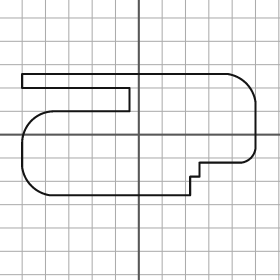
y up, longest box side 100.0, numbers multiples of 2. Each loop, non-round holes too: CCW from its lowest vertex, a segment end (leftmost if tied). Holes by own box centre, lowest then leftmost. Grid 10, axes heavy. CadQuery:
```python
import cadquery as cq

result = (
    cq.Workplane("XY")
    .moveTo(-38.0, -26.0)
    .lineTo(22.0, -26.0)
    .lineTo(22.0, -18.0)
    .lineTo(26.0, -18.0)
    .lineTo(26.0, -12.0)
    .lineTo(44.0, -12.0)
    .threePointArc((48.0, -10.0), (50.0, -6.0))
    .lineTo(50.0, 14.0)
    .threePointArc((46.0, 22.0), (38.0, 26.0))
    .lineTo(-50.0, 26.0)
    .lineTo(-50.0, 20.0)
    .lineTo(-4.0, 20.0)
    .lineTo(-4.0, 10.0)
    .lineTo(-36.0, 10.0)
    .threePointArc((-46.0, 6.0), (-50.0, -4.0))
    .lineTo(-50.0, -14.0)
    .threePointArc((-46.0, -22.0), (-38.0, -26.0))
    .close()
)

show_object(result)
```